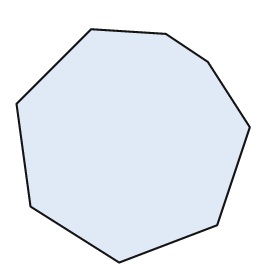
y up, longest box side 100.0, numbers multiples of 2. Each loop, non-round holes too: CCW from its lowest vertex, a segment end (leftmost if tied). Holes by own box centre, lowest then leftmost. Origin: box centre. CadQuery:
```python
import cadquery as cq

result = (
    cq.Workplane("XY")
    .moveTo(-6.0, -50.0)
    .lineTo(36.0, -34.0)
    .lineTo(50.0, 8.0)
    .lineTo(32.0, 36.0)
    .lineTo(14.0, 48.0)
    .lineTo(-18.0, 50.0)
    .lineTo(-50.0, 18.0)
    .lineTo(-44.0, -26.0)
    .close()
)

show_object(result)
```